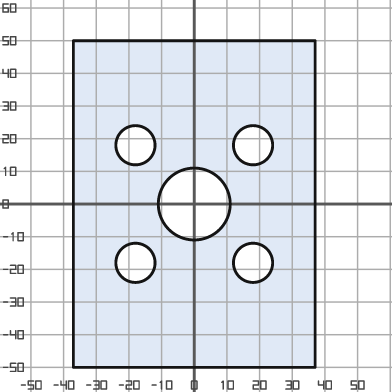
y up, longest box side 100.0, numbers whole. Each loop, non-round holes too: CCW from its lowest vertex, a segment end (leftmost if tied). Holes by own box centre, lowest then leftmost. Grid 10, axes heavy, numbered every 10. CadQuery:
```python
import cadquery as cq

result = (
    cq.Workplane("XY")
    .moveTo(-37.0, -50.0)
    .lineTo(37.0, -50.0)
    .lineTo(37.0, 50.0)
    .lineTo(-37.0, 50.0)
    .close()
    .moveTo(-18.0, -18.0)
    .circle(6.0)
    .moveTo(18.0, -18.0)
    .circle(6.0)
    .moveTo(0.0, 0.0)
    .circle(11.0)
    .moveTo(-18.0, 18.0)
    .circle(6.0)
    .moveTo(18.0, 18.0)
    .circle(6.0)
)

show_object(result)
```